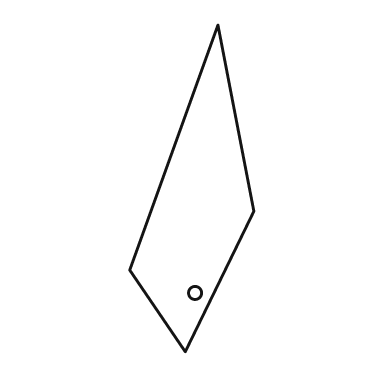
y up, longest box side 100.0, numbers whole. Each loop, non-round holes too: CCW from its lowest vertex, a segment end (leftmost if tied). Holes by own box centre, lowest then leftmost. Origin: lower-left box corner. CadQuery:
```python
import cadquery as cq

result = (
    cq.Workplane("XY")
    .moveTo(17.0, 0.0)
    .lineTo(38.0, 43.0)
    .lineTo(27.0, 100.0)
    .lineTo(0.0, 25.0)
    .close()
    .moveTo(20.0, 18.0)
    .circle(2.0)
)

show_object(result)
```